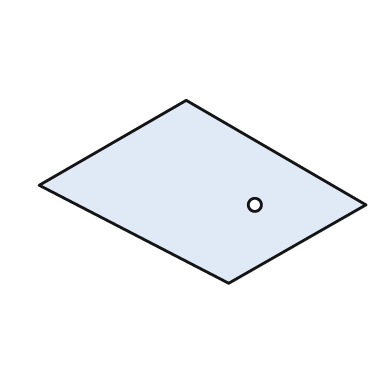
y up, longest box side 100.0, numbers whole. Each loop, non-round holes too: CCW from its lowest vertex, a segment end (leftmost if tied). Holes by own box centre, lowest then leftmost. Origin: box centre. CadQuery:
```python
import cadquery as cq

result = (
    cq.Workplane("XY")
    .moveTo(8.0, -28.0)
    .lineTo(50.0, -4.0)
    .lineTo(-5.0, 28.0)
    .lineTo(-50.0, 2.0)
    .close()
    .moveTo(16.0, -4.0)
    .circle(2.0)
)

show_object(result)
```